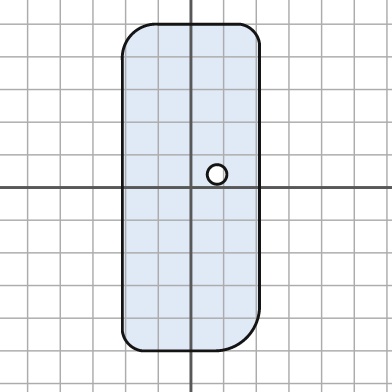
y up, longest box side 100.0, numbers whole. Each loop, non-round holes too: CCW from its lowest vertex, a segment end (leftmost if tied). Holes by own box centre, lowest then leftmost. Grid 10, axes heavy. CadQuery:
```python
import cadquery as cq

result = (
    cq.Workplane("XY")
    .moveTo(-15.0, -50.0)
    .lineTo(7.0, -50.0)
    .threePointArc((17.0, -46.0), (21.0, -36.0))
    .lineTo(21.0, 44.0)
    .threePointArc((19.0, 48.0), (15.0, 50.0))
    .lineTo(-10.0, 50.0)
    .threePointArc((-18.0, 47.0), (-21.0, 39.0))
    .lineTo(-21.0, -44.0)
    .threePointArc((-19.0, -48.0), (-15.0, -50.0))
    .close()
    .moveTo(8.0, 4.0)
    .circle(3.0)
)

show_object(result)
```